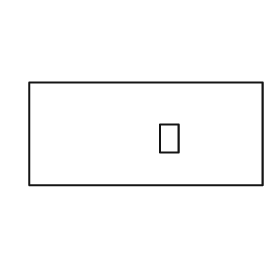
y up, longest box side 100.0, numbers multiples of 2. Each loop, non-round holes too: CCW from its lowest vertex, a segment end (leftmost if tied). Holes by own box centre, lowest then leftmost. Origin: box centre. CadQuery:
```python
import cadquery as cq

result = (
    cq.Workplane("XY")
    .moveTo(-50.0, -22.0)
    .lineTo(50.0, -22.0)
    .lineTo(50.0, 22.0)
    .lineTo(-50.0, 22.0)
    .close()
    .moveTo(6.0, -8.0)
    .lineTo(14.0, -8.0)
    .lineTo(14.0, 4.0)
    .lineTo(6.0, 4.0)
    .close()
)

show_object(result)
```